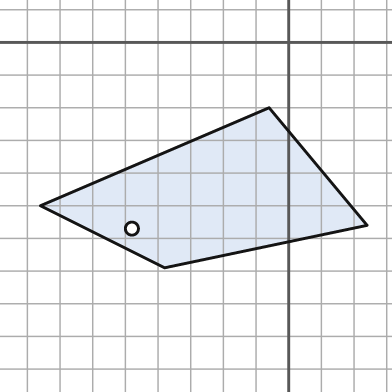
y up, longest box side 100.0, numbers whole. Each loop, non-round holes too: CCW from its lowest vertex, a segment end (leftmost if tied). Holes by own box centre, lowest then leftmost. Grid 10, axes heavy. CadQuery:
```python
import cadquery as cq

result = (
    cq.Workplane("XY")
    .moveTo(-38.0, -69.0)
    .lineTo(24.0, -56.0)
    .lineTo(-6.0, -20.0)
    .lineTo(-76.0, -50.0)
    .close()
    .moveTo(-48.0, -57.0)
    .circle(2.0)
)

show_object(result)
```